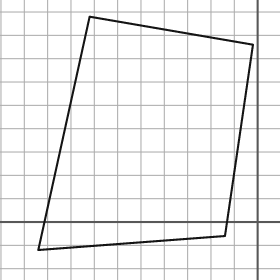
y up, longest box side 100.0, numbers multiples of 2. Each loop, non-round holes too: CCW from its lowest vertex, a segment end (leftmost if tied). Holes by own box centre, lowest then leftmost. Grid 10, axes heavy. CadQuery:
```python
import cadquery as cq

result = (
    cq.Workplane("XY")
    .moveTo(-94.0, -12.0)
    .lineTo(-14.0, -6.0)
    .lineTo(-2.0, 76.0)
    .lineTo(-72.0, 88.0)
    .close()
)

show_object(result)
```